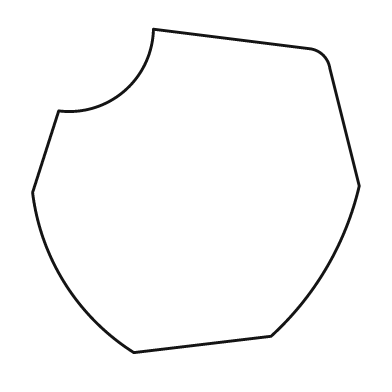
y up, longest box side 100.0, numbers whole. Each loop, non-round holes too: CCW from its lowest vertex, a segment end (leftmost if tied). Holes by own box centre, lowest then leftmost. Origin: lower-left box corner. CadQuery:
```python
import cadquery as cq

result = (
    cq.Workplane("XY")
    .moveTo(31.0, 0.0)
    .lineTo(73.0, 5.0)
    .threePointArc((90.0, 26.0), (100.0, 51.0))
    .lineTo(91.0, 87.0)
    .threePointArc((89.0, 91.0), (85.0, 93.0))
    .lineTo(37.0, 99.0)
    .threePointArc((28.0, 80.0), (8.0, 74.0))
    .lineTo(0.0, 49.0)
    .threePointArc((10.0, 21.0), (31.0, 0.0))
    .close()
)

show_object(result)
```